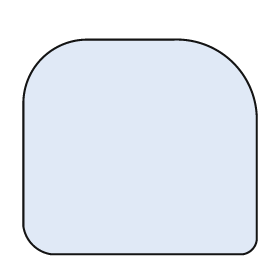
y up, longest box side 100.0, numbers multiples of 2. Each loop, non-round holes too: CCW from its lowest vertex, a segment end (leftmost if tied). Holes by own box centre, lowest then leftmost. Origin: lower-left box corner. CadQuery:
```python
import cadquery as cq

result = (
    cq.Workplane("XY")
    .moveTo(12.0, 0.0)
    .lineTo(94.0, 0.0)
    .threePointArc((98.0, 2.0), (100.0, 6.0))
    .lineTo(100.0, 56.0)
    .threePointArc((90.0, 82.0), (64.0, 92.0))
    .lineTo(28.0, 92.0)
    .threePointArc((8.0, 84.0), (0.0, 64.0))
    .lineTo(0.0, 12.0)
    .threePointArc((4.0, 4.0), (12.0, 0.0))
    .close()
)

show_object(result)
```